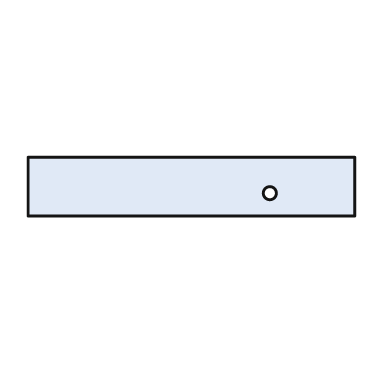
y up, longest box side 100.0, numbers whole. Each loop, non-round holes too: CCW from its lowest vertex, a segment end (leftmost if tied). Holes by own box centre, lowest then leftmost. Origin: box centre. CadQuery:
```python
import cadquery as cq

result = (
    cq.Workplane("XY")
    .moveTo(-50.0, -9.0)
    .lineTo(50.0, -9.0)
    .lineTo(50.0, 9.0)
    .lineTo(-50.0, 9.0)
    .close()
    .moveTo(24.0, -2.0)
    .circle(2.0)
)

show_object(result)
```